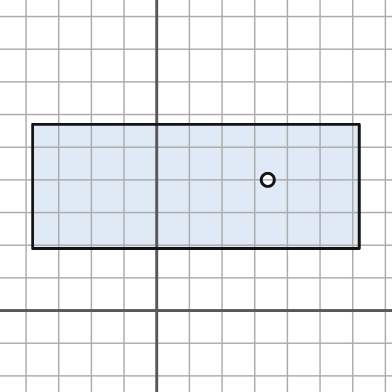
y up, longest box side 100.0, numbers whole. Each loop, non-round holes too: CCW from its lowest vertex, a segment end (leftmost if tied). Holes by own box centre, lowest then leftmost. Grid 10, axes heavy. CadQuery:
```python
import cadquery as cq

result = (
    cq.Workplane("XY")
    .moveTo(-38.0, 19.0)
    .lineTo(62.0, 19.0)
    .lineTo(62.0, 57.0)
    .lineTo(-38.0, 57.0)
    .close()
    .moveTo(34.0, 40.0)
    .circle(2.0)
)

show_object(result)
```